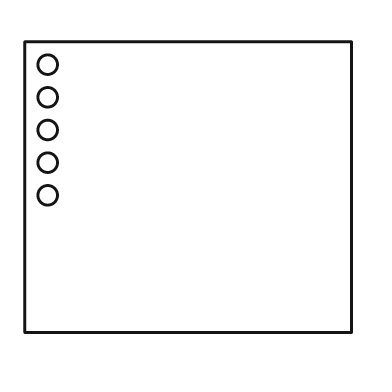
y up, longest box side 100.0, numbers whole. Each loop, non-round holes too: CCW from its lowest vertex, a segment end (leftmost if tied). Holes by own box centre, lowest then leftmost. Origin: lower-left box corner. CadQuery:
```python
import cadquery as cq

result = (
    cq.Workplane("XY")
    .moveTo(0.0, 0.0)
    .lineTo(100.0, 0.0)
    .lineTo(100.0, 89.0)
    .lineTo(0.0, 89.0)
    .close()
    .moveTo(7.0, 42.0)
    .circle(3.0)
    .moveTo(7.0, 52.0)
    .circle(3.0)
    .moveTo(7.0, 62.0)
    .circle(3.0)
    .moveTo(7.0, 72.0)
    .circle(3.0)
    .moveTo(7.0, 82.0)
    .circle(3.0)
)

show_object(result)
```